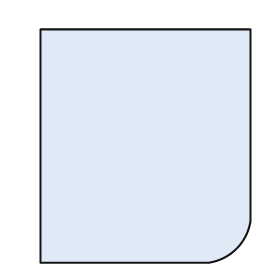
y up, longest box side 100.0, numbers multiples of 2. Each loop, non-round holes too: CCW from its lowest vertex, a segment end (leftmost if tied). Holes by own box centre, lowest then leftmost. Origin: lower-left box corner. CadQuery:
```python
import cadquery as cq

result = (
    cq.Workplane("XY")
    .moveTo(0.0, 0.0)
    .lineTo(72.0, 0.0)
    .threePointArc((84.0, 6.0), (90.0, 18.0))
    .lineTo(90.0, 100.0)
    .lineTo(0.0, 100.0)
    .close()
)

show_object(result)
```